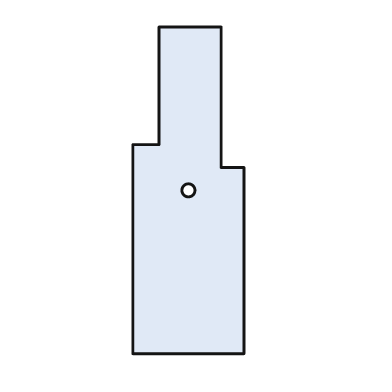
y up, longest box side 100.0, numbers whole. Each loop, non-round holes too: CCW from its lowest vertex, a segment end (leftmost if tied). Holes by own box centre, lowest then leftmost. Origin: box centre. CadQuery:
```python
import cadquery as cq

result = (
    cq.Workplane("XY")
    .moveTo(-17.0, -50.0)
    .lineTo(17.0, -50.0)
    .lineTo(17.0, 7.0)
    .lineTo(10.0, 7.0)
    .lineTo(10.0, 50.0)
    .lineTo(-9.0, 50.0)
    .lineTo(-9.0, 14.0)
    .lineTo(-17.0, 14.0)
    .close()
    .moveTo(0.0, 0.0)
    .circle(2.0)
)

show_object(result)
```